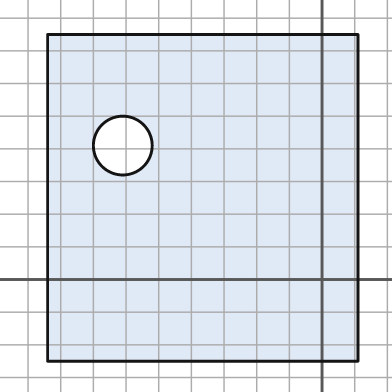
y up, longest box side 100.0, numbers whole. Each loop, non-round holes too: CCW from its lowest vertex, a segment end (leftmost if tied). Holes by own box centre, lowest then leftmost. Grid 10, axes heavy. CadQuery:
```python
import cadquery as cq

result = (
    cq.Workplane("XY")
    .moveTo(-84.0, -25.0)
    .lineTo(11.0, -25.0)
    .lineTo(11.0, 75.0)
    .lineTo(-84.0, 75.0)
    .close()
    .moveTo(-61.0, 41.0)
    .circle(9.0)
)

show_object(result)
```